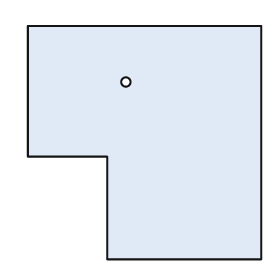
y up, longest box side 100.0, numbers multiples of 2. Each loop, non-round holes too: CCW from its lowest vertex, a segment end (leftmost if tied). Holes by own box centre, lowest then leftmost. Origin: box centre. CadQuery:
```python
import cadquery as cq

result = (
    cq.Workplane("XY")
    .moveTo(-16.0, -50.0)
    .lineTo(50.0, -50.0)
    .lineTo(50.0, 50.0)
    .lineTo(-50.0, 50.0)
    .lineTo(-50.0, -6.0)
    .lineTo(-16.0, -6.0)
    .close()
    .moveTo(-8.0, 26.0)
    .circle(2.0)
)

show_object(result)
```